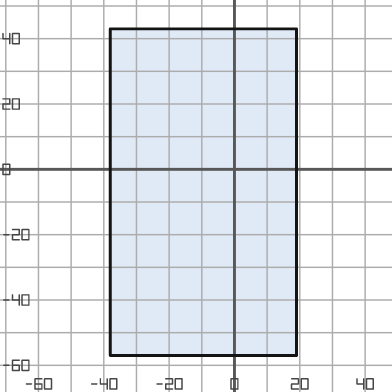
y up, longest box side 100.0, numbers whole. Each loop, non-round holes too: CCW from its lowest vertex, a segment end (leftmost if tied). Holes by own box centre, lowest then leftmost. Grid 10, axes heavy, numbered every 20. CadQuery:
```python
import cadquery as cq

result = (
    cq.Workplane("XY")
    .moveTo(-38.0, -57.0)
    .lineTo(19.0, -57.0)
    .lineTo(19.0, 43.0)
    .lineTo(-38.0, 43.0)
    .close()
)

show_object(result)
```